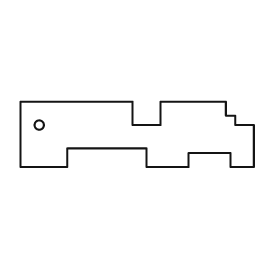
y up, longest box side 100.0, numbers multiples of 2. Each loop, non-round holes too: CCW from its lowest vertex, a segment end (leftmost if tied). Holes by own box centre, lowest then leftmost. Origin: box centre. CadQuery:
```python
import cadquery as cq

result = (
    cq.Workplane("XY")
    .moveTo(-50.0, -14.0)
    .lineTo(-30.0, -14.0)
    .lineTo(-30.0, -6.0)
    .lineTo(4.0, -6.0)
    .lineTo(4.0, -14.0)
    .lineTo(22.0, -14.0)
    .lineTo(22.0, -8.0)
    .lineTo(40.0, -8.0)
    .lineTo(40.0, -14.0)
    .lineTo(50.0, -14.0)
    .lineTo(50.0, 4.0)
    .lineTo(42.0, 4.0)
    .lineTo(42.0, 8.0)
    .lineTo(38.0, 8.0)
    .lineTo(38.0, 14.0)
    .lineTo(10.0, 14.0)
    .lineTo(10.0, 4.0)
    .lineTo(-2.0, 4.0)
    .lineTo(-2.0, 14.0)
    .lineTo(-50.0, 14.0)
    .close()
    .moveTo(-42.0, 4.0)
    .circle(2.0)
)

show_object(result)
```